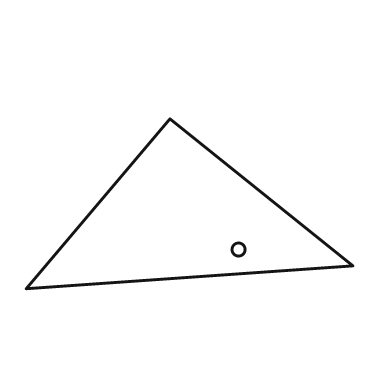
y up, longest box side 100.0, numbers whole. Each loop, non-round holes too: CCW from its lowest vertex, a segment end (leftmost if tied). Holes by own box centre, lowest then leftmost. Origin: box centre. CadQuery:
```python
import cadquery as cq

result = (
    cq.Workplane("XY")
    .moveTo(-50.0, -26.0)
    .lineTo(50.0, -19.0)
    .lineTo(-6.0, 26.0)
    .close()
    .moveTo(15.0, -14.0)
    .circle(2.0)
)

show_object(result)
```